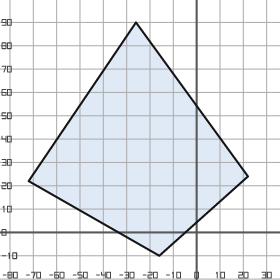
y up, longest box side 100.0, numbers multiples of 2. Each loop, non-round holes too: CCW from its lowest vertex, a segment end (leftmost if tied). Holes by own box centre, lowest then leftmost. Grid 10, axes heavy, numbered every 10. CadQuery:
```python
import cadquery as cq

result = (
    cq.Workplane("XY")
    .moveTo(-16.0, -10.0)
    .lineTo(22.0, 24.0)
    .lineTo(-26.0, 90.0)
    .lineTo(-72.0, 22.0)
    .close()
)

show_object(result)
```